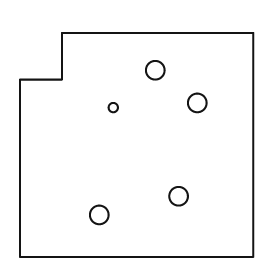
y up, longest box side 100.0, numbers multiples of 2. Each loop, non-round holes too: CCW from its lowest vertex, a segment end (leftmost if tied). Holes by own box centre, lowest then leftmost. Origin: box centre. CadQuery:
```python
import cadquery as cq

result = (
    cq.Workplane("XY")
    .moveTo(-50.0, -48.0)
    .lineTo(50.0, -48.0)
    .lineTo(50.0, 48.0)
    .lineTo(-32.0, 48.0)
    .lineTo(-32.0, 28.0)
    .lineTo(-50.0, 28.0)
    .close()
    .moveTo(-16.0, -30.0)
    .circle(4.0)
    .moveTo(18.0, -22.0)
    .circle(4.0)
    .moveTo(-10.0, 16.0)
    .circle(2.0)
    .moveTo(26.0, 18.0)
    .circle(4.0)
    .moveTo(8.0, 32.0)
    .circle(4.0)
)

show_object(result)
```